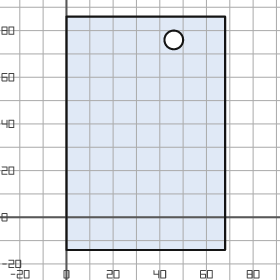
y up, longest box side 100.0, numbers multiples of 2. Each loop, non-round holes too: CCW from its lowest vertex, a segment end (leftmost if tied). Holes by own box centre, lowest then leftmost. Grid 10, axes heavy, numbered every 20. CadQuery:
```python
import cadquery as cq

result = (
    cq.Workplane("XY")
    .moveTo(0.0, -14.0)
    .lineTo(68.0, -14.0)
    .lineTo(68.0, 86.0)
    .lineTo(0.0, 86.0)
    .close()
    .moveTo(46.0, 76.0)
    .circle(4.0)
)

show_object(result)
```